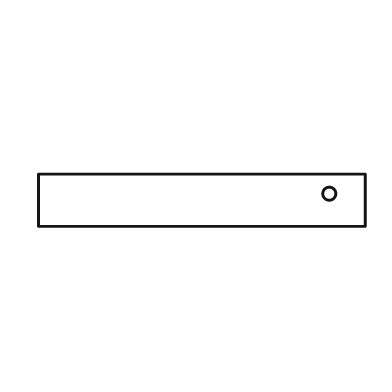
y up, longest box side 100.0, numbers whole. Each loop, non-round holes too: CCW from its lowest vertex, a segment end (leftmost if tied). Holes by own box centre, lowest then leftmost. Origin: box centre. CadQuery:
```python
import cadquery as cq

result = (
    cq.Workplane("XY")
    .moveTo(-50.0, -8.0)
    .lineTo(50.0, -8.0)
    .lineTo(50.0, 8.0)
    .lineTo(-50.0, 8.0)
    .close()
    .moveTo(39.0, 2.0)
    .circle(2.0)
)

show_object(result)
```